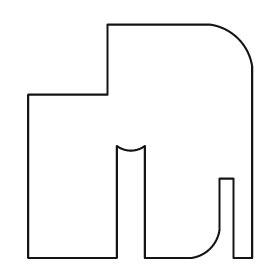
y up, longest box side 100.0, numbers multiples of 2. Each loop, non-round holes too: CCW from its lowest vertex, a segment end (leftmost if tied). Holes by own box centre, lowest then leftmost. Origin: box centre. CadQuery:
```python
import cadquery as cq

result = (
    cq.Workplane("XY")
    .moveTo(-48.0, -50.0)
    .lineTo(-10.0, -50.0)
    .lineTo(-10.0, -2.0)
    .threePointArc((-4.0, -4.0), (2.0, -2.0))
    .lineTo(2.0, -50.0)
    .lineTo(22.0, -50.0)
    .threePointArc((30.0, -46.0), (34.0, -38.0))
    .lineTo(34.0, -16.0)
    .lineTo(40.0, -16.0)
    .lineTo(40.0, -50.0)
    .lineTo(48.0, -50.0)
    .lineTo(48.0, 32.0)
    .threePointArc((42.0, 44.0), (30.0, 50.0))
    .lineTo(-14.0, 50.0)
    .lineTo(-14.0, 20.0)
    .lineTo(-48.0, 20.0)
    .close()
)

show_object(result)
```